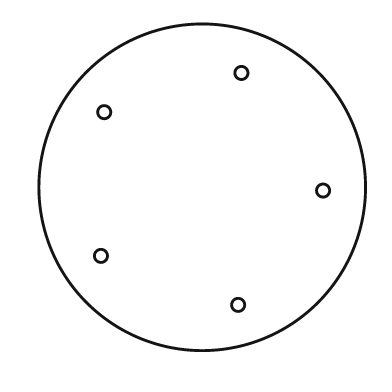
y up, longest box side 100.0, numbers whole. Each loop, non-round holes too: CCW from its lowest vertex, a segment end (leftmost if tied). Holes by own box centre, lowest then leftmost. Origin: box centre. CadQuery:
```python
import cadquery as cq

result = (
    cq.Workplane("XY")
    .moveTo(0.0, 0.0)
    .circle(50.0)
    .moveTo(11.0, -36.0)
    .circle(2.0)
    .moveTo(-31.0, -21.0)
    .circle(2.0)
    .moveTo(37.0, -1.0)
    .circle(2.0)
    .moveTo(-30.0, 23.0)
    .circle(2.0)
    .moveTo(12.0, 35.0)
    .circle(2.0)
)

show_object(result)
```